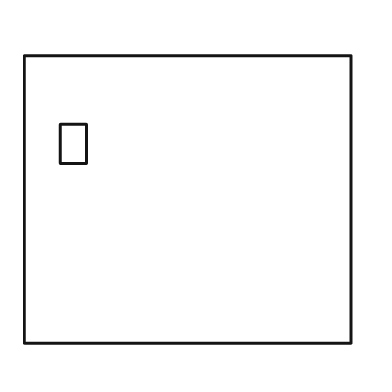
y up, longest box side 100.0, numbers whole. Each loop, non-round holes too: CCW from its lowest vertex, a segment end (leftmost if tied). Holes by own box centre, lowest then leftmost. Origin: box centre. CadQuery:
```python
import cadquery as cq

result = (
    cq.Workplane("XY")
    .moveTo(-50.0, -44.0)
    .lineTo(50.0, -44.0)
    .lineTo(50.0, 44.0)
    .lineTo(-50.0, 44.0)
    .close()
    .moveTo(-39.0, 11.0)
    .lineTo(-31.0, 11.0)
    .lineTo(-31.0, 23.0)
    .lineTo(-39.0, 23.0)
    .close()
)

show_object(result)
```